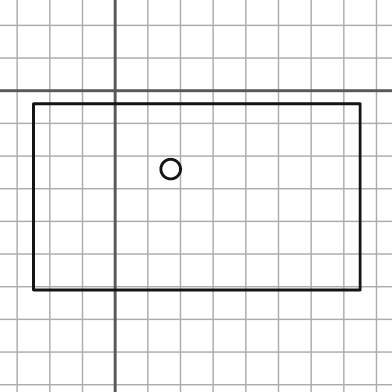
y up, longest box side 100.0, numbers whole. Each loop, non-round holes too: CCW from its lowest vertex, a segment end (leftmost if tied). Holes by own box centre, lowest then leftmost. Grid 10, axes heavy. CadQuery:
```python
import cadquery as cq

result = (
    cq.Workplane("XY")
    .moveTo(-25.0, -61.0)
    .lineTo(75.0, -61.0)
    .lineTo(75.0, -4.0)
    .lineTo(-25.0, -4.0)
    .close()
    .moveTo(17.0, -24.0)
    .circle(3.0)
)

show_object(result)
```